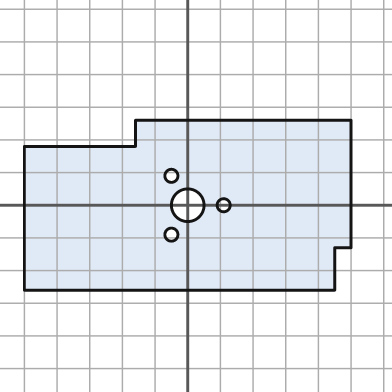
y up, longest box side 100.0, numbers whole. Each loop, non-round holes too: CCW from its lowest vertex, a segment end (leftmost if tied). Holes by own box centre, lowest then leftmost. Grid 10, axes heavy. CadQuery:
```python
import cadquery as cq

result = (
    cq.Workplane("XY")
    .moveTo(-50.0, -26.0)
    .lineTo(45.0, -26.0)
    .lineTo(45.0, -13.0)
    .lineTo(50.0, -13.0)
    .lineTo(50.0, 26.0)
    .lineTo(-16.0, 26.0)
    .lineTo(-16.0, 18.0)
    .lineTo(-50.0, 18.0)
    .close()
    .moveTo(-5.0, -9.0)
    .circle(2.0)
    .moveTo(0.0, 0.0)
    .circle(5.0)
    .moveTo(11.0, 0.0)
    .circle(2.0)
    .moveTo(-5.0, 9.0)
    .circle(2.0)
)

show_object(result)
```